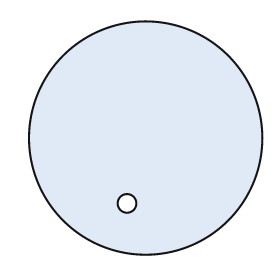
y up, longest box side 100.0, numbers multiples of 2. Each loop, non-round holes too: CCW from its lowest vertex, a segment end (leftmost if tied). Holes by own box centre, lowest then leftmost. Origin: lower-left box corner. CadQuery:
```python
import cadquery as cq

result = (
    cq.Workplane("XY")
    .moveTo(50.0, 50.0)
    .circle(50.0)
    .moveTo(42.0, 22.0)
    .circle(4.0)
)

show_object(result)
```